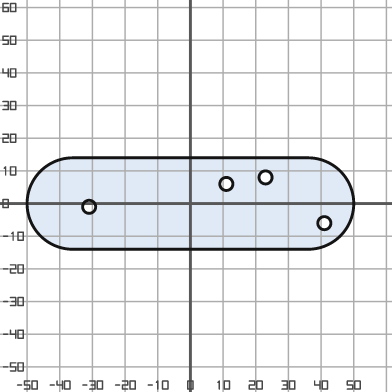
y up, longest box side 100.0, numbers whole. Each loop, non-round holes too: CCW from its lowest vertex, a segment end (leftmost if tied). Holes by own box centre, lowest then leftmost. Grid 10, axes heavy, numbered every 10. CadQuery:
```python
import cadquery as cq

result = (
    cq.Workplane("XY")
    .moveTo(-36.0, -14.0)
    .lineTo(36.0, -14.0)
    .threePointArc((50.0, 0.0), (36.0, 14.0))
    .lineTo(-36.0, 14.0)
    .threePointArc((-50.0, 0.0), (-36.0, -14.0))
    .close()
    .moveTo(41.0, -6.0)
    .circle(2.0)
    .moveTo(-31.0, -1.0)
    .circle(2.0)
    .moveTo(11.0, 6.0)
    .circle(2.0)
    .moveTo(23.0, 8.0)
    .circle(2.0)
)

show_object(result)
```